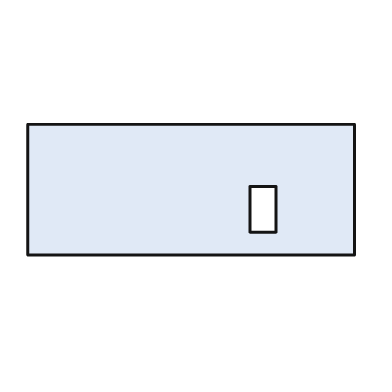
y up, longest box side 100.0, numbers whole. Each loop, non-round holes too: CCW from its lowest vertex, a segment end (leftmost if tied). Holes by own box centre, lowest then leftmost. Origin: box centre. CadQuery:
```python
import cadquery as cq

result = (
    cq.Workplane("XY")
    .moveTo(-50.0, -20.0)
    .lineTo(50.0, -20.0)
    .lineTo(50.0, 20.0)
    .lineTo(-50.0, 20.0)
    .close()
    .moveTo(18.0, -13.0)
    .lineTo(26.0, -13.0)
    .lineTo(26.0, 1.0)
    .lineTo(18.0, 1.0)
    .close()
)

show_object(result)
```